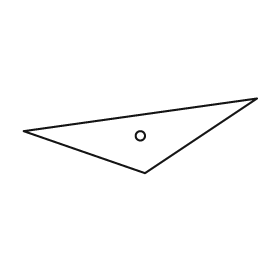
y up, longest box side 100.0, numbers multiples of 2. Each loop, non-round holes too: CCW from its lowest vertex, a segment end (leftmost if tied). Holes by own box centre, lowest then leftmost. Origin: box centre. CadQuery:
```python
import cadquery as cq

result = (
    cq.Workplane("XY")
    .moveTo(2.0, -16.0)
    .lineTo(50.0, 16.0)
    .lineTo(-50.0, 2.0)
    .close()
    .moveTo(0.0, 0.0)
    .circle(2.0)
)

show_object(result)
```